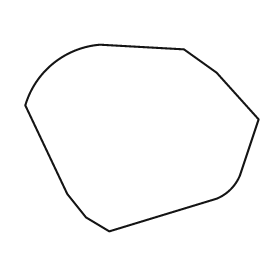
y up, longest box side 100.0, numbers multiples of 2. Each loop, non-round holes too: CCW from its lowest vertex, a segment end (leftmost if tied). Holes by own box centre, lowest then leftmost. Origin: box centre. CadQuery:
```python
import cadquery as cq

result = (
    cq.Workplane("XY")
    .moveTo(-14.0, -40.0)
    .lineTo(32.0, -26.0)
    .threePointArc((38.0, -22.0), (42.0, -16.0))
    .lineTo(50.0, 8.0)
    .lineTo(32.0, 28.0)
    .lineTo(18.0, 38.0)
    .lineTo(-18.0, 40.0)
    .threePointArc((-38.0, 32.0), (-50.0, 14.0))
    .lineTo(-32.0, -24.0)
    .lineTo(-24.0, -34.0)
    .close()
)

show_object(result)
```